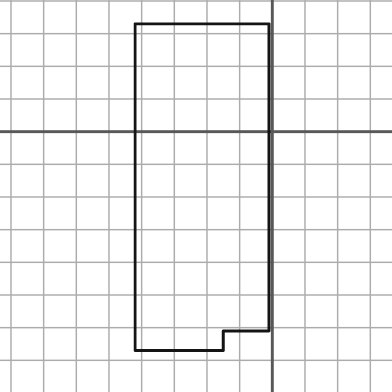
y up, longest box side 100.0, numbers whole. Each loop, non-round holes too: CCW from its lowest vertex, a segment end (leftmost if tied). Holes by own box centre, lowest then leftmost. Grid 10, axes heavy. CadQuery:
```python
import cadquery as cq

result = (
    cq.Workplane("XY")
    .moveTo(-42.0, -67.0)
    .lineTo(-15.0, -67.0)
    .lineTo(-15.0, -61.0)
    .lineTo(-1.0, -61.0)
    .lineTo(-1.0, 33.0)
    .lineTo(-42.0, 33.0)
    .close()
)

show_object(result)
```